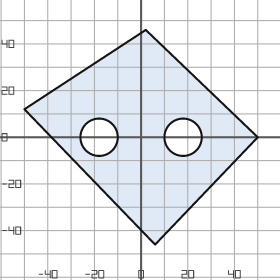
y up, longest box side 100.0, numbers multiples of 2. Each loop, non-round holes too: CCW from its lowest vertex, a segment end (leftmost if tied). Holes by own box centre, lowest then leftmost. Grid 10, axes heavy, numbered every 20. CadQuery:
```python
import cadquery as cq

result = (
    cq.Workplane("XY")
    .moveTo(6.0, -46.0)
    .lineTo(50.0, 0.0)
    .lineTo(2.0, 46.0)
    .lineTo(-50.0, 12.0)
    .close()
    .moveTo(-18.0, 0.0)
    .circle(8.0)
    .moveTo(18.0, 0.0)
    .circle(8.0)
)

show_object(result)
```